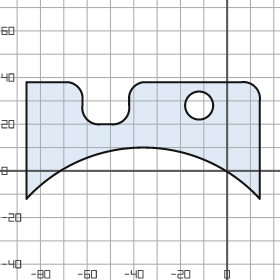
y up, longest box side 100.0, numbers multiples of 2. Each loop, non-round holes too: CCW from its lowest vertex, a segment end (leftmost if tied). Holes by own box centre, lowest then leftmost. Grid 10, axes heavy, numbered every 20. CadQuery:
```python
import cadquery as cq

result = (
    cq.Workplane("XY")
    .moveTo(-86.0, -12.0)
    .threePointArc((-36.0, 10.0), (14.0, -12.0))
    .lineTo(14.0, 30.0)
    .threePointArc((12.0, 36.0), (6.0, 38.0))
    .lineTo(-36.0, 38.0)
    .threePointArc((-40.0, 36.0), (-42.0, 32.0))
    .lineTo(-42.0, 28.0)
    .threePointArc((-44.0, 22.0), (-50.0, 20.0))
    .lineTo(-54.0, 20.0)
    .threePointArc((-60.0, 22.0), (-62.0, 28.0))
    .lineTo(-62.0, 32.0)
    .threePointArc((-64.0, 36.0), (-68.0, 38.0))
    .lineTo(-86.0, 38.0)
    .close()
    .moveTo(-12.0, 28.0)
    .circle(6.0)
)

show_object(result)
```